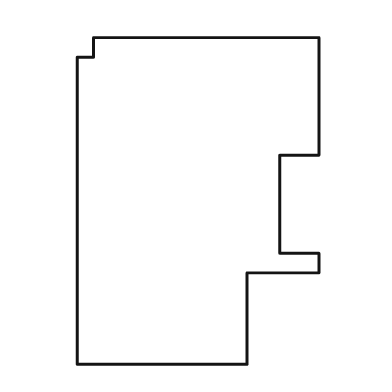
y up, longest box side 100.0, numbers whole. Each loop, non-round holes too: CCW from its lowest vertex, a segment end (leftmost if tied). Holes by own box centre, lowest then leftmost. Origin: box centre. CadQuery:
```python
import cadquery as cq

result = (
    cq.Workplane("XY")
    .moveTo(-37.0, -50.0)
    .lineTo(15.0, -50.0)
    .lineTo(15.0, -22.0)
    .lineTo(37.0, -22.0)
    .lineTo(37.0, -16.0)
    .lineTo(25.0, -16.0)
    .lineTo(25.0, 14.0)
    .lineTo(37.0, 14.0)
    .lineTo(37.0, 50.0)
    .lineTo(-32.0, 50.0)
    .lineTo(-32.0, 44.0)
    .lineTo(-37.0, 44.0)
    .close()
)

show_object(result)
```